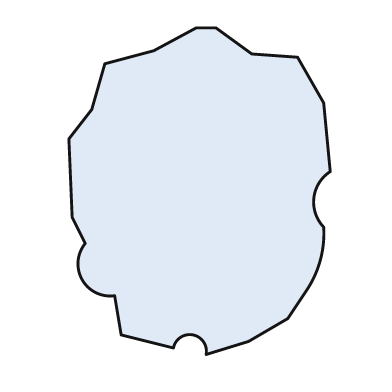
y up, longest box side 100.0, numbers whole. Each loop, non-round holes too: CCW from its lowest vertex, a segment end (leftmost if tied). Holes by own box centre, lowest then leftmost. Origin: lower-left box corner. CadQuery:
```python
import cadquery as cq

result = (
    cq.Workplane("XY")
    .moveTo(42.0, 0.0)
    .lineTo(55.0, 4.0)
    .lineTo(67.0, 11.0)
    .lineTo(73.0, 20.0)
    .threePointArc((77.0, 29.0), (78.0, 39.0))
    .threePointArc((75.0, 48.0), (80.0, 56.0))
    .lineTo(78.0, 77.0)
    .lineTo(70.0, 91.0)
    .lineTo(56.0, 92.0)
    .lineTo(45.0, 100.0)
    .lineTo(39.0, 100.0)
    .lineTo(26.0, 93.0)
    .lineTo(11.0, 89.0)
    .lineTo(7.0, 75.0)
    .lineTo(0.0, 66.0)
    .lineTo(1.0, 42.0)
    .lineTo(5.0, 34.0)
    .threePointArc((4.0, 23.0), (14.0, 18.0))
    .lineTo(16.0, 6.0)
    .lineTo(32.0, 2.0)
    .threePointArc((38.0, 6.0), (42.0, 0.0))
    .close()
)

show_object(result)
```